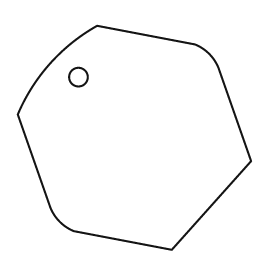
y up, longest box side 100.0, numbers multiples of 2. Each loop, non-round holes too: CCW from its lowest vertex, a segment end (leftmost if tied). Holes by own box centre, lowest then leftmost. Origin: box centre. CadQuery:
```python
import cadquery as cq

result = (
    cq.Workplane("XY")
    .moveTo(16.0, -48.0)
    .lineTo(50.0, -10.0)
    .lineTo(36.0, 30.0)
    .threePointArc((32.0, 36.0), (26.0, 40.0))
    .lineTo(-16.0, 48.0)
    .threePointArc((-36.0, 32.0), (-50.0, 10.0))
    .lineTo(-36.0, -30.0)
    .threePointArc((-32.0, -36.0), (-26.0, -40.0))
    .close()
    .moveTo(-24.0, 26.0)
    .circle(4.0)
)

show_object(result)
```